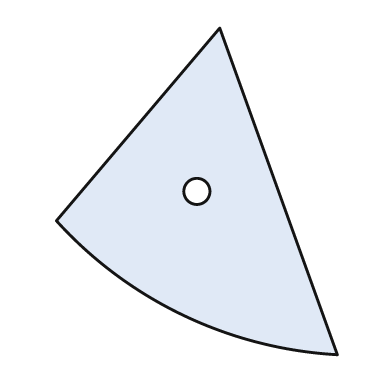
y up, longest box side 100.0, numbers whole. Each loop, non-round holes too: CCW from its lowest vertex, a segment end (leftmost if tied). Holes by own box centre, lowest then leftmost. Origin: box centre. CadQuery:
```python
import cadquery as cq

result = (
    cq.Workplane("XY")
    .moveTo(43.0, -50.0)
    .lineTo(7.0, 50.0)
    .lineTo(-43.0, -9.0)
    .threePointArc((-4.0, -38.0), (43.0, -50.0))
    .close()
    .moveTo(0.0, 0.0)
    .circle(4.0)
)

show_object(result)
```